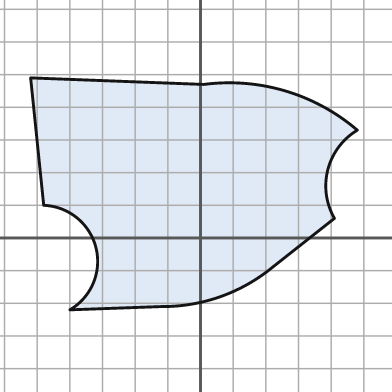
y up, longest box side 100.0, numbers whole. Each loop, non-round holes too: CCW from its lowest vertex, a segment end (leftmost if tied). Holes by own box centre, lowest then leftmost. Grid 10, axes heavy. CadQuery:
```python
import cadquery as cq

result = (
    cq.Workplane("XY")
    .moveTo(-40.0, -22.0)
    .lineTo(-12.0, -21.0)
    .threePointArc((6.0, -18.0), (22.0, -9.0))
    .lineTo(41.0, 6.0)
    .threePointArc((39.0, 21.0), (48.0, 33.0))
    .threePointArc((26.0, 45.0), (1.0, 47.0))
    .lineTo(-52.0, 49.0)
    .lineTo(-48.0, 10.0)
    .threePointArc((-32.0, -3.0), (-40.0, -22.0))
    .close()
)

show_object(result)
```